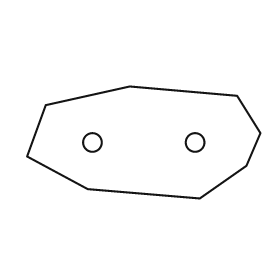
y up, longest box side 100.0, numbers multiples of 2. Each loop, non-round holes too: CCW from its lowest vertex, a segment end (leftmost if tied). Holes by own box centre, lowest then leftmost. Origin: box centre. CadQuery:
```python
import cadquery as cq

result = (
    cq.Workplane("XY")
    .moveTo(24.0, -24.0)
    .lineTo(44.0, -10.0)
    .lineTo(50.0, 4.0)
    .lineTo(40.0, 20.0)
    .lineTo(-6.0, 24.0)
    .lineTo(-42.0, 16.0)
    .lineTo(-50.0, -6.0)
    .lineTo(-24.0, -20.0)
    .close()
    .moveTo(-22.0, 0.0)
    .circle(4.0)
    .moveTo(22.0, 0.0)
    .circle(4.0)
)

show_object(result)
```